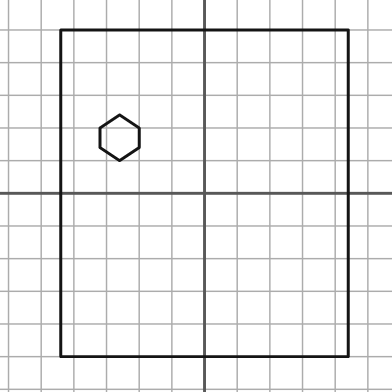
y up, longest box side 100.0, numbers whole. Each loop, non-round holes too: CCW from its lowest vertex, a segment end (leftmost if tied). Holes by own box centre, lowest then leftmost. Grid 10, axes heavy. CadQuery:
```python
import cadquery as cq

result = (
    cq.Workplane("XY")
    .moveTo(-44.0, -50.0)
    .lineTo(44.0, -50.0)
    .lineTo(44.0, 50.0)
    .lineTo(-44.0, 50.0)
    .close()
    .moveTo(-26.0, 10.0)
    .lineTo(-20.0, 14.0)
    .lineTo(-20.0, 20.0)
    .lineTo(-26.0, 24.0)
    .lineTo(-32.0, 20.0)
    .lineTo(-32.0, 14.0)
    .close()
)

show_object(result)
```